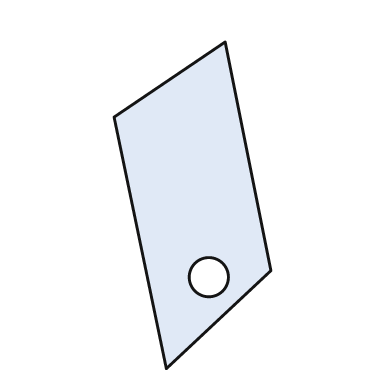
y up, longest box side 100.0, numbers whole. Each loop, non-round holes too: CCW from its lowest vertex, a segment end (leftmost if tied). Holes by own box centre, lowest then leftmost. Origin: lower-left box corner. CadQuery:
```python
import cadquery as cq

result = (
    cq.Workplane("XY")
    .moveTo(16.0, 0.0)
    .lineTo(48.0, 30.0)
    .lineTo(34.0, 100.0)
    .lineTo(0.0, 77.0)
    .close()
    .moveTo(29.0, 28.0)
    .circle(6.0)
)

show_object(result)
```